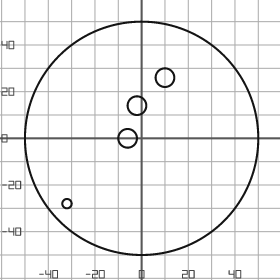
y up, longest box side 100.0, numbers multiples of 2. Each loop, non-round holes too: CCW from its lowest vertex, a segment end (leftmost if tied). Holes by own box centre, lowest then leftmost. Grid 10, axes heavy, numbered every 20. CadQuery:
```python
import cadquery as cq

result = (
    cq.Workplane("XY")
    .moveTo(0.0, 0.0)
    .circle(50.0)
    .moveTo(-32.0, -28.0)
    .circle(2.0)
    .moveTo(-6.0, 0.0)
    .circle(4.0)
    .moveTo(-2.0, 14.0)
    .circle(4.0)
    .moveTo(10.0, 26.0)
    .circle(4.0)
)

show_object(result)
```